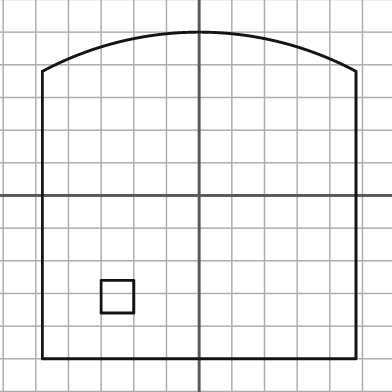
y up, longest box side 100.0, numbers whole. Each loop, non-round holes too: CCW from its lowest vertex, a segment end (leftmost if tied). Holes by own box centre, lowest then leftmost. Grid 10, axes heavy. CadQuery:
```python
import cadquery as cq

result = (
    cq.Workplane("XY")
    .moveTo(-48.0, -50.0)
    .lineTo(48.0, -50.0)
    .lineTo(48.0, 38.0)
    .threePointArc((0.0, 50.0), (-48.0, 38.0))
    .close()
    .moveTo(-30.0, -36.0)
    .lineTo(-20.0, -36.0)
    .lineTo(-20.0, -26.0)
    .lineTo(-30.0, -26.0)
    .close()
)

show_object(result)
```